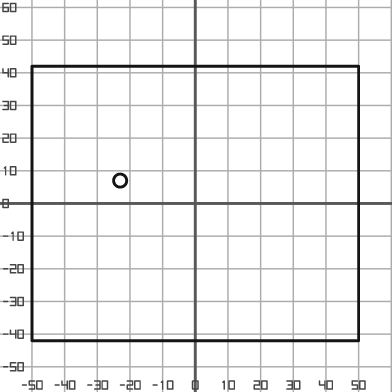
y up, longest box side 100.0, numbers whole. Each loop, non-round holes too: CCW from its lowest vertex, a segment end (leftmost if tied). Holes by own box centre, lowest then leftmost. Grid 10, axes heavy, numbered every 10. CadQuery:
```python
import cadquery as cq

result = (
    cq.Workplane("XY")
    .moveTo(-50.0, -42.0)
    .lineTo(50.0, -42.0)
    .lineTo(50.0, 42.0)
    .lineTo(-50.0, 42.0)
    .close()
    .moveTo(-23.0, 7.0)
    .circle(2.0)
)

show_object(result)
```